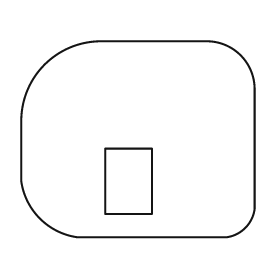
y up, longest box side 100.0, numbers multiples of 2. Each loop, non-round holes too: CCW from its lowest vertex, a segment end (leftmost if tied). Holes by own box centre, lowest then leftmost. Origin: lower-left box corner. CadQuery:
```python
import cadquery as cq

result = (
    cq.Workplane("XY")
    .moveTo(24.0, 0.0)
    .lineTo(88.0, 0.0)
    .threePointArc((96.0, 4.0), (100.0, 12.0))
    .lineTo(100.0, 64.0)
    .threePointArc((94.0, 78.0), (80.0, 84.0))
    .lineTo(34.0, 84.0)
    .threePointArc((10.0, 74.0), (0.0, 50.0))
    .lineTo(0.0, 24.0)
    .threePointArc((8.0, 8.0), (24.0, 0.0))
    .close()
    .moveTo(36.0, 10.0)
    .lineTo(56.0, 10.0)
    .lineTo(56.0, 38.0)
    .lineTo(36.0, 38.0)
    .close()
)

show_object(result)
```